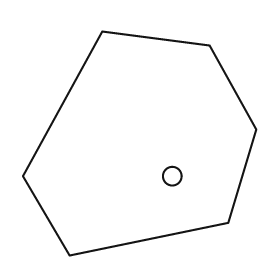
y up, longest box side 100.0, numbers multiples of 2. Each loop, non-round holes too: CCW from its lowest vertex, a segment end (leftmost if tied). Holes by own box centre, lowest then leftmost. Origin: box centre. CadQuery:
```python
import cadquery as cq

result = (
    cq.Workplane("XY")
    .moveTo(-30.0, -48.0)
    .lineTo(38.0, -34.0)
    .lineTo(50.0, 6.0)
    .lineTo(30.0, 42.0)
    .lineTo(-16.0, 48.0)
    .lineTo(-50.0, -14.0)
    .close()
    .moveTo(14.0, -14.0)
    .circle(4.0)
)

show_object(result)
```